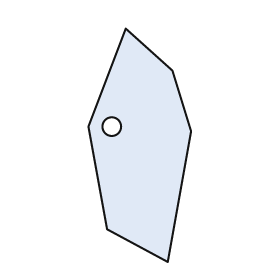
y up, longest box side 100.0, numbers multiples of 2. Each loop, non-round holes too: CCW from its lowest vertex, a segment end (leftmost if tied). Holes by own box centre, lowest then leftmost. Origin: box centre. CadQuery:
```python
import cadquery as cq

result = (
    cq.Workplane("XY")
    .moveTo(12.0, -50.0)
    .lineTo(22.0, 6.0)
    .lineTo(14.0, 32.0)
    .lineTo(-6.0, 50.0)
    .lineTo(-22.0, 8.0)
    .lineTo(-14.0, -36.0)
    .close()
    .moveTo(-12.0, 8.0)
    .circle(4.0)
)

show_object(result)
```